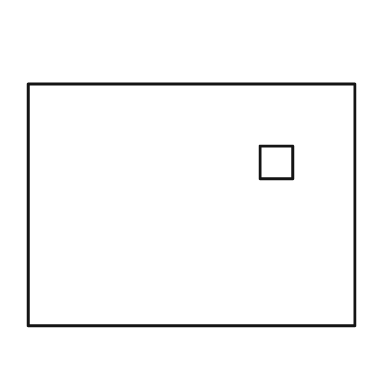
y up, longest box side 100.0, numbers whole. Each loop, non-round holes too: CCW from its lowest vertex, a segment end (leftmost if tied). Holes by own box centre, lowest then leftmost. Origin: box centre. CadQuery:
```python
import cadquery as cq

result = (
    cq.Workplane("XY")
    .moveTo(-50.0, -37.0)
    .lineTo(50.0, -37.0)
    .lineTo(50.0, 37.0)
    .lineTo(-50.0, 37.0)
    .close()
    .moveTo(21.0, 8.0)
    .lineTo(31.0, 8.0)
    .lineTo(31.0, 18.0)
    .lineTo(21.0, 18.0)
    .close()
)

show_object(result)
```